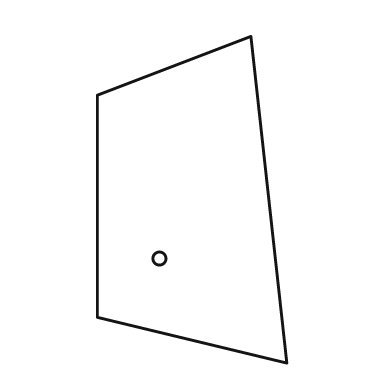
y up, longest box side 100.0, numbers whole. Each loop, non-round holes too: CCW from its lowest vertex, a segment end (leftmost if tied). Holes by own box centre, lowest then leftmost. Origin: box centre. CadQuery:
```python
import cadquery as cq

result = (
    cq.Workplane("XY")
    .moveTo(29.0, -50.0)
    .lineTo(18.0, 50.0)
    .lineTo(-29.0, 32.0)
    .lineTo(-29.0, -36.0)
    .close()
    .moveTo(-10.0, -18.0)
    .circle(2.0)
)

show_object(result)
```